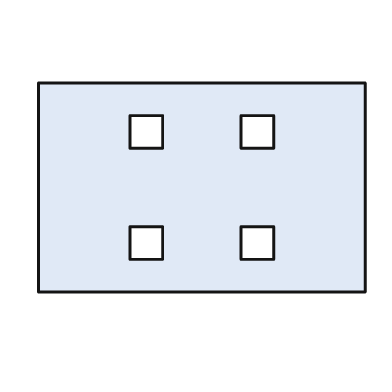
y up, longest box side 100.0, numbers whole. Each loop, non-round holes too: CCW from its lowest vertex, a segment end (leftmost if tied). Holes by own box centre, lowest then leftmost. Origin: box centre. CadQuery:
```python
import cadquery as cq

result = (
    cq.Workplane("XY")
    .moveTo(-50.0, -32.0)
    .lineTo(50.0, -32.0)
    .lineTo(50.0, 32.0)
    .lineTo(-50.0, 32.0)
    .close()
    .moveTo(-22.0, -22.0)
    .lineTo(-12.0, -22.0)
    .lineTo(-12.0, -12.0)
    .lineTo(-22.0, -12.0)
    .close()
    .moveTo(12.0, -22.0)
    .lineTo(22.0, -22.0)
    .lineTo(22.0, -12.0)
    .lineTo(12.0, -12.0)
    .close()
    .moveTo(-22.0, 12.0)
    .lineTo(-12.0, 12.0)
    .lineTo(-12.0, 22.0)
    .lineTo(-22.0, 22.0)
    .close()
    .moveTo(12.0, 12.0)
    .lineTo(22.0, 12.0)
    .lineTo(22.0, 22.0)
    .lineTo(12.0, 22.0)
    .close()
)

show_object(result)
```